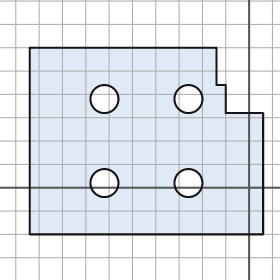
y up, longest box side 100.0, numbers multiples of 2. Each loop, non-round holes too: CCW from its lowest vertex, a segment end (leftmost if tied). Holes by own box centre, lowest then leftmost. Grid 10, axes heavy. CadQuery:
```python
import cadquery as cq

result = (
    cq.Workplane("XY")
    .moveTo(-94.0, -20.0)
    .lineTo(6.0, -20.0)
    .lineTo(6.0, 32.0)
    .lineTo(-10.0, 32.0)
    .lineTo(-10.0, 44.0)
    .lineTo(-14.0, 44.0)
    .lineTo(-14.0, 60.0)
    .lineTo(-94.0, 60.0)
    .close()
    .moveTo(-62.0, 2.0)
    .circle(6.0)
    .moveTo(-26.0, 2.0)
    .circle(6.0)
    .moveTo(-62.0, 38.0)
    .circle(6.0)
    .moveTo(-26.0, 38.0)
    .circle(6.0)
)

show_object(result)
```